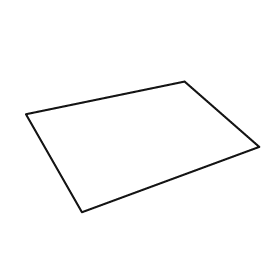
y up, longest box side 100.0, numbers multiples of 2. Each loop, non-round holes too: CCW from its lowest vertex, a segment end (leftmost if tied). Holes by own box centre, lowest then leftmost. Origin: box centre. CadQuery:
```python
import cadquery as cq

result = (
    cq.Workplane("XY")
    .moveTo(-26.0, -28.0)
    .lineTo(50.0, 0.0)
    .lineTo(18.0, 28.0)
    .lineTo(-50.0, 14.0)
    .close()
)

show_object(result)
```